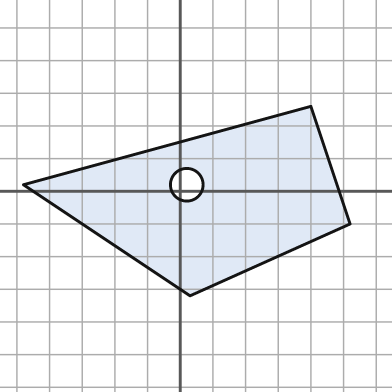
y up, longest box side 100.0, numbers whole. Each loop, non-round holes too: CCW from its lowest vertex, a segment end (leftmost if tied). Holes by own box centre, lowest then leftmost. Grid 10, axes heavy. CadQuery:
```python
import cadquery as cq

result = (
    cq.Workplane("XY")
    .moveTo(3.0, -32.0)
    .lineTo(52.0, -10.0)
    .lineTo(40.0, 26.0)
    .lineTo(-48.0, 2.0)
    .close()
    .moveTo(2.0, 2.0)
    .circle(5.0)
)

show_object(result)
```